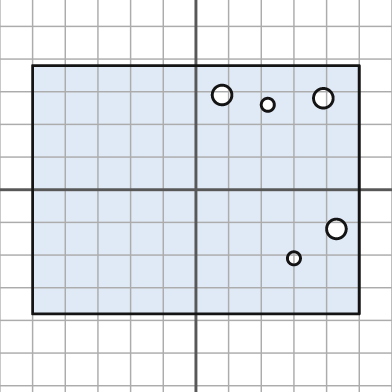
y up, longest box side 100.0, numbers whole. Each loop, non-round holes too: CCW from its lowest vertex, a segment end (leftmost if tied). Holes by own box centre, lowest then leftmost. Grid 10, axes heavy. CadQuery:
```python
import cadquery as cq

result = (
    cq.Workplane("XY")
    .moveTo(-50.0, -38.0)
    .lineTo(50.0, -38.0)
    .lineTo(50.0, 38.0)
    .lineTo(-50.0, 38.0)
    .close()
    .moveTo(30.0, -21.0)
    .circle(2.0)
    .moveTo(43.0, -12.0)
    .circle(3.0)
    .moveTo(22.0, 26.0)
    .circle(2.0)
    .moveTo(39.0, 28.0)
    .circle(3.0)
    .moveTo(8.0, 29.0)
    .circle(3.0)
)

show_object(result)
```